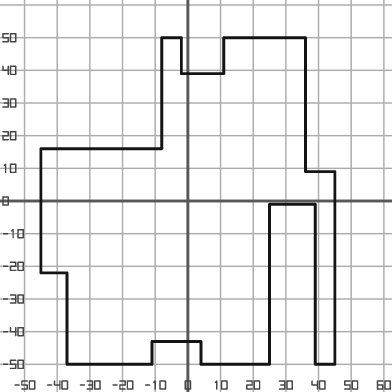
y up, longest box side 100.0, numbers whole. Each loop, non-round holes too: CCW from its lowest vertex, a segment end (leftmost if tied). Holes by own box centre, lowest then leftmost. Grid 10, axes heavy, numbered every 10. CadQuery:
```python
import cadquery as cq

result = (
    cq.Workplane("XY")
    .moveTo(-37.0, -50.0)
    .lineTo(-11.0, -50.0)
    .lineTo(-11.0, -43.0)
    .lineTo(4.0, -43.0)
    .lineTo(4.0, -50.0)
    .lineTo(25.0, -50.0)
    .lineTo(25.0, -1.0)
    .lineTo(39.0, -1.0)
    .lineTo(39.0, -50.0)
    .lineTo(45.0, -50.0)
    .lineTo(45.0, 9.0)
    .lineTo(36.0, 9.0)
    .lineTo(36.0, 50.0)
    .lineTo(11.0, 50.0)
    .lineTo(11.0, 39.0)
    .lineTo(-2.0, 39.0)
    .lineTo(-2.0, 50.0)
    .lineTo(-8.0, 50.0)
    .lineTo(-8.0, 16.0)
    .lineTo(-45.0, 16.0)
    .lineTo(-45.0, -22.0)
    .lineTo(-37.0, -22.0)
    .close()
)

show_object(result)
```